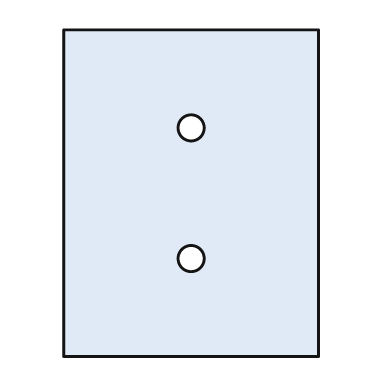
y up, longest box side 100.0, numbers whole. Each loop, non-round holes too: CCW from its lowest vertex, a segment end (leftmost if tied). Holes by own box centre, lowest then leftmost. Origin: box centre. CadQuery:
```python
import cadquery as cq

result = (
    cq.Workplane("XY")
    .moveTo(-39.0, -50.0)
    .lineTo(39.0, -50.0)
    .lineTo(39.0, 50.0)
    .lineTo(-39.0, 50.0)
    .close()
    .moveTo(0.0, -20.0)
    .circle(4.0)
    .moveTo(0.0, 20.0)
    .circle(4.0)
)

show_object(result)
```